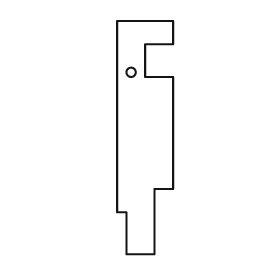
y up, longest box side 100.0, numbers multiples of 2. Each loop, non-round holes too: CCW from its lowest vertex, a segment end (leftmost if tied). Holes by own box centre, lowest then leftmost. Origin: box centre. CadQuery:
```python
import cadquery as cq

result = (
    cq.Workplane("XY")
    .moveTo(-8.0, -50.0)
    .lineTo(4.0, -50.0)
    .lineTo(4.0, -22.0)
    .lineTo(12.0, -22.0)
    .lineTo(12.0, 26.0)
    .lineTo(0.0, 26.0)
    .lineTo(0.0, 40.0)
    .lineTo(12.0, 40.0)
    .lineTo(12.0, 50.0)
    .lineTo(-12.0, 50.0)
    .lineTo(-12.0, -32.0)
    .lineTo(-8.0, -32.0)
    .close()
    .moveTo(-6.0, 28.0)
    .circle(2.0)
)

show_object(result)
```